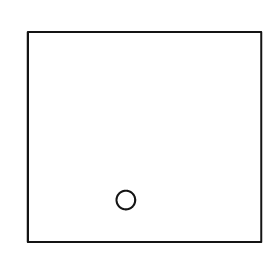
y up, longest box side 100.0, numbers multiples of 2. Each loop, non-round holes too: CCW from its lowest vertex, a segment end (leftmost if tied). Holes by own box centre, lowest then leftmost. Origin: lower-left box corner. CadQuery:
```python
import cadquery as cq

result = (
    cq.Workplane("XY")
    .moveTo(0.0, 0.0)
    .lineTo(100.0, 0.0)
    .lineTo(100.0, 90.0)
    .lineTo(0.0, 90.0)
    .close()
    .moveTo(42.0, 18.0)
    .circle(4.0)
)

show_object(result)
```